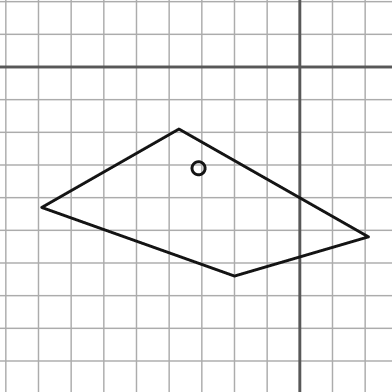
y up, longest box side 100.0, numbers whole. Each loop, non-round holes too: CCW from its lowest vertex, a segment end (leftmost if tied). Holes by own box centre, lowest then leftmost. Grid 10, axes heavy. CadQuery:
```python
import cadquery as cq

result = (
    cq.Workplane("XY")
    .moveTo(-20.0, -64.0)
    .lineTo(21.0, -52.0)
    .lineTo(-37.0, -19.0)
    .lineTo(-79.0, -43.0)
    .close()
    .moveTo(-31.0, -31.0)
    .circle(2.0)
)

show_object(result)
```